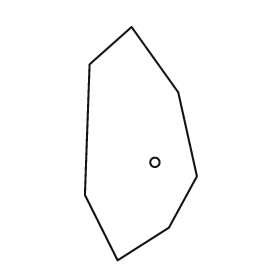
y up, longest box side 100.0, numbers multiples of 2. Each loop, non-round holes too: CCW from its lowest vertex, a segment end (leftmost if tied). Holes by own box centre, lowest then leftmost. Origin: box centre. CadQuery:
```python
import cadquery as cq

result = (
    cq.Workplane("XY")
    .moveTo(-10.0, -50.0)
    .lineTo(12.0, -36.0)
    .lineTo(24.0, -14.0)
    .lineTo(16.0, 22.0)
    .lineTo(-4.0, 50.0)
    .lineTo(-22.0, 34.0)
    .lineTo(-24.0, -22.0)
    .close()
    .moveTo(6.0, -8.0)
    .circle(2.0)
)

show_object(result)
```